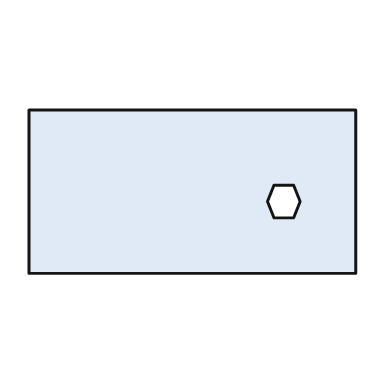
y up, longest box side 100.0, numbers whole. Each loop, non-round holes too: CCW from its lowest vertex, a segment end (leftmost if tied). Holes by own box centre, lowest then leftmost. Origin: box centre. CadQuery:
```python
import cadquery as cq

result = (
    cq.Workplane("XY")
    .moveTo(-50.0, -25.0)
    .lineTo(50.0, -25.0)
    .lineTo(50.0, 25.0)
    .lineTo(-50.0, 25.0)
    .close()
    .moveTo(25.0, -8.0)
    .lineTo(31.0, -8.0)
    .lineTo(33.0, -3.0)
    .lineTo(31.0, 2.0)
    .lineTo(25.0, 2.0)
    .lineTo(23.0, -3.0)
    .close()
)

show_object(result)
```